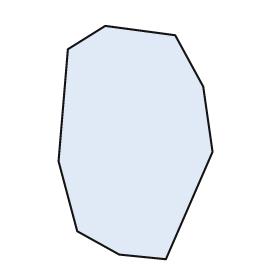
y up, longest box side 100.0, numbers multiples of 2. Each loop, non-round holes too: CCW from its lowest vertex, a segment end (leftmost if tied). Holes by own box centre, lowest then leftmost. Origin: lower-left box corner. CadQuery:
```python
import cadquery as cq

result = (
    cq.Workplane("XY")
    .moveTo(46.0, 0.0)
    .lineTo(66.0, 46.0)
    .lineTo(62.0, 74.0)
    .lineTo(50.0, 96.0)
    .lineTo(20.0, 100.0)
    .lineTo(4.0, 90.0)
    .lineTo(0.0, 42.0)
    .lineTo(8.0, 12.0)
    .lineTo(26.0, 2.0)
    .close()
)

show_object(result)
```